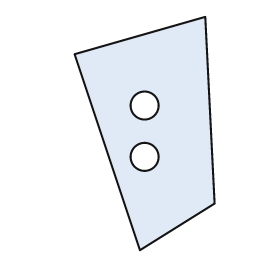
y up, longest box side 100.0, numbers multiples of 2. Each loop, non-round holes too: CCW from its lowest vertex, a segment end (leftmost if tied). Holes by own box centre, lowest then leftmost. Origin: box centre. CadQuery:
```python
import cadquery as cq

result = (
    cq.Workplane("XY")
    .moveTo(-2.0, -50.0)
    .lineTo(30.0, -30.0)
    .lineTo(26.0, 50.0)
    .lineTo(-30.0, 34.0)
    .close()
    .moveTo(0.0, -10.0)
    .circle(6.0)
    .moveTo(0.0, 12.0)
    .circle(6.0)
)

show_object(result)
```